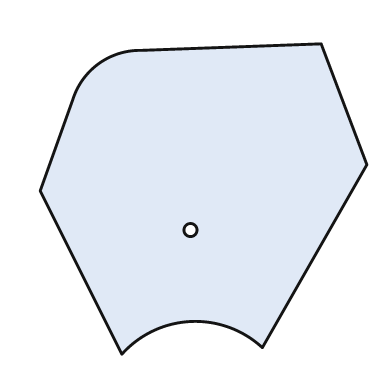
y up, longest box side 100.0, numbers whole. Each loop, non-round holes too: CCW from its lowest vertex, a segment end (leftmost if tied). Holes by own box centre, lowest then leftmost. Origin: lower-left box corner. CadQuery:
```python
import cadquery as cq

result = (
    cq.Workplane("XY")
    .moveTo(25.0, 0.0)
    .threePointArc((46.0, 10.0), (68.0, 2.0))
    .lineTo(100.0, 58.0)
    .lineTo(86.0, 95.0)
    .lineTo(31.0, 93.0)
    .threePointArc((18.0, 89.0), (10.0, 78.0))
    .lineTo(0.0, 50.0)
    .close()
    .moveTo(46.0, 38.0)
    .circle(2.0)
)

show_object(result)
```